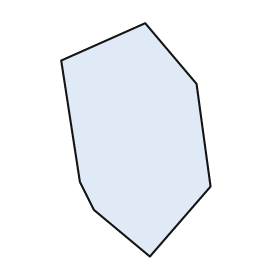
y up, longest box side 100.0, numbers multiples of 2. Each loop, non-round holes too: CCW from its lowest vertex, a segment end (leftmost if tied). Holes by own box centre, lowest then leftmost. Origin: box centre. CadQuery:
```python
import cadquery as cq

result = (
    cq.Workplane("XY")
    .moveTo(6.0, -50.0)
    .lineTo(32.0, -20.0)
    .lineTo(26.0, 24.0)
    .lineTo(4.0, 50.0)
    .lineTo(-32.0, 34.0)
    .lineTo(-24.0, -18.0)
    .lineTo(-18.0, -30.0)
    .close()
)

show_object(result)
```